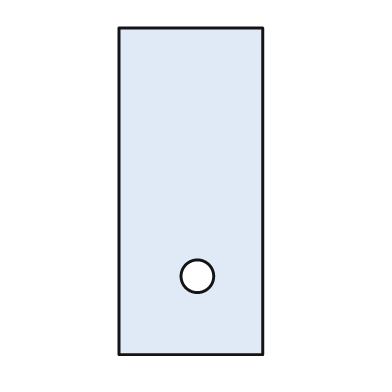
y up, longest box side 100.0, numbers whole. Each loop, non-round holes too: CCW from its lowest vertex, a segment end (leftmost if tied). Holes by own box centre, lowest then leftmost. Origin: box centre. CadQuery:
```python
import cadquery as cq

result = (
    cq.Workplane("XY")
    .moveTo(-22.0, -50.0)
    .lineTo(22.0, -50.0)
    .lineTo(22.0, 50.0)
    .lineTo(-22.0, 50.0)
    .close()
    .moveTo(2.0, -26.0)
    .circle(5.0)
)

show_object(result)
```